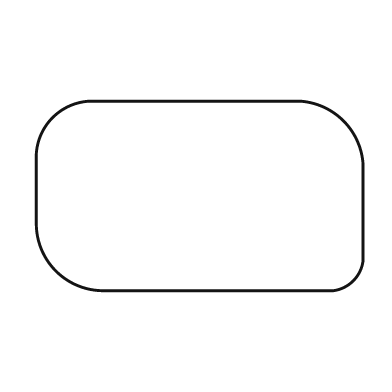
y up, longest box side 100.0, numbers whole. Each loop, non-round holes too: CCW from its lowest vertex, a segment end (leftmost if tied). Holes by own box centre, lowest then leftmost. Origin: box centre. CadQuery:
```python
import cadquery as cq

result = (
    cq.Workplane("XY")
    .moveTo(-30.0, -29.0)
    .lineTo(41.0, -29.0)
    .threePointArc((47.0, -26.0), (50.0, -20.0))
    .lineTo(50.0, 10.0)
    .threePointArc((44.0, 23.0), (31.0, 29.0))
    .lineTo(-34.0, 29.0)
    .threePointArc((-45.0, 24.0), (-50.0, 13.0))
    .lineTo(-50.0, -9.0)
    .threePointArc((-44.0, -23.0), (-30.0, -29.0))
    .close()
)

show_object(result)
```